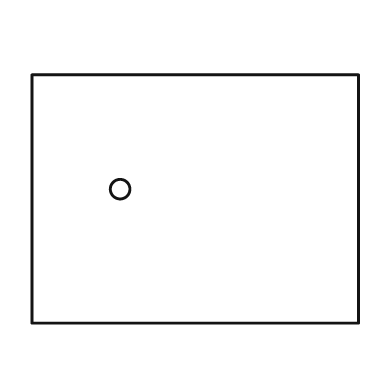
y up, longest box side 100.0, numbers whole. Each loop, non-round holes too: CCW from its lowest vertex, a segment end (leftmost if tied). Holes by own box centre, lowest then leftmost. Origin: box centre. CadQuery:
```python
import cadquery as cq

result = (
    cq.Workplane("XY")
    .moveTo(-50.0, -38.0)
    .lineTo(50.0, -38.0)
    .lineTo(50.0, 38.0)
    .lineTo(-50.0, 38.0)
    .close()
    .moveTo(-23.0, 3.0)
    .circle(3.0)
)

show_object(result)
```